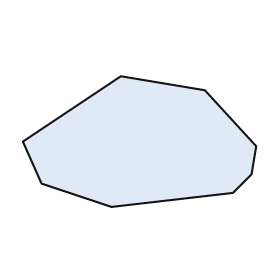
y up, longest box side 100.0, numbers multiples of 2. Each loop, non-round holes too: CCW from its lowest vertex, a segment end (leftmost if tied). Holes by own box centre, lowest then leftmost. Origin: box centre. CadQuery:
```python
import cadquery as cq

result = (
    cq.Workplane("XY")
    .moveTo(-12.0, -28.0)
    .lineTo(40.0, -22.0)
    .lineTo(48.0, -14.0)
    .lineTo(50.0, -2.0)
    .lineTo(28.0, 22.0)
    .lineTo(-8.0, 28.0)
    .lineTo(-50.0, 0.0)
    .lineTo(-42.0, -18.0)
    .close()
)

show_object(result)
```